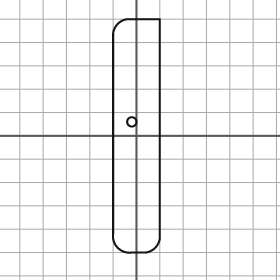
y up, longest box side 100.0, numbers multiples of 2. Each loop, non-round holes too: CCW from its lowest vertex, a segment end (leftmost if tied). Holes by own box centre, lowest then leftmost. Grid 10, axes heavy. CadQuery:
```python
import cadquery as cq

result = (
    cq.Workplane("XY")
    .moveTo(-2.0, -50.0)
    .lineTo(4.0, -50.0)
    .threePointArc((8.0, -48.0), (10.0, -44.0))
    .lineTo(10.0, 50.0)
    .lineTo(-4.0, 50.0)
    .threePointArc((-8.0, 48.0), (-10.0, 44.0))
    .lineTo(-10.0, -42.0)
    .threePointArc((-8.0, -48.0), (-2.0, -50.0))
    .close()
    .moveTo(-2.0, 6.0)
    .circle(2.0)
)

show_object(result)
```